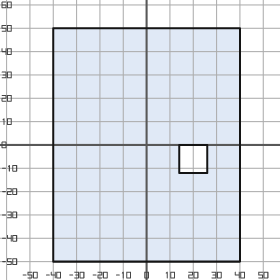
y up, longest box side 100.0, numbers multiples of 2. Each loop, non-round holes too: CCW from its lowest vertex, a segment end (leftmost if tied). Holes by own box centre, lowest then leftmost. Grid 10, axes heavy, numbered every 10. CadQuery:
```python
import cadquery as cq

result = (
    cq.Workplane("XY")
    .moveTo(-40.0, -50.0)
    .lineTo(40.0, -50.0)
    .lineTo(40.0, 50.0)
    .lineTo(-40.0, 50.0)
    .close()
    .moveTo(14.0, -12.0)
    .lineTo(26.0, -12.0)
    .lineTo(26.0, 0.0)
    .lineTo(14.0, 0.0)
    .close()
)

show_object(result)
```